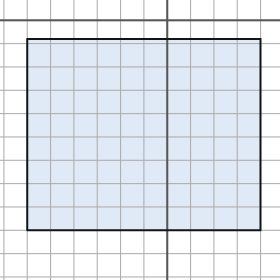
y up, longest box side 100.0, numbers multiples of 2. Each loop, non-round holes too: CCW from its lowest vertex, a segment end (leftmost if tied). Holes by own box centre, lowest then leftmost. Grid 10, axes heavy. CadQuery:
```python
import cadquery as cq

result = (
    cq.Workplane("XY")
    .moveTo(-60.0, -90.0)
    .lineTo(40.0, -90.0)
    .lineTo(40.0, -8.0)
    .lineTo(-60.0, -8.0)
    .close()
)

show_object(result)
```